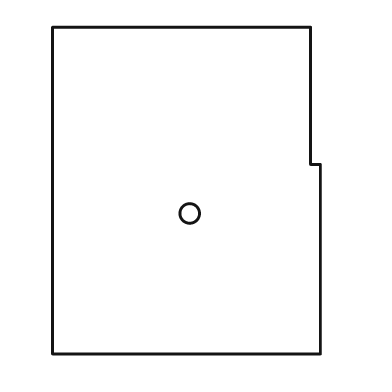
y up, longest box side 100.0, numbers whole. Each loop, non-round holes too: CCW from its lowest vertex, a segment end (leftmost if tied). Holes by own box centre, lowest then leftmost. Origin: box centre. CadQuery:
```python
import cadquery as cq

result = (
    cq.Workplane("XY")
    .moveTo(-41.0, -50.0)
    .lineTo(41.0, -50.0)
    .lineTo(41.0, 8.0)
    .lineTo(38.0, 8.0)
    .lineTo(38.0, 50.0)
    .lineTo(-41.0, 50.0)
    .close()
    .moveTo(1.0, -7.0)
    .circle(3.0)
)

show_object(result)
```